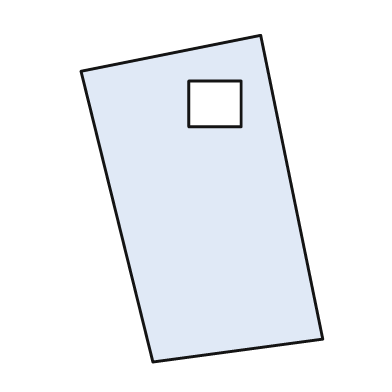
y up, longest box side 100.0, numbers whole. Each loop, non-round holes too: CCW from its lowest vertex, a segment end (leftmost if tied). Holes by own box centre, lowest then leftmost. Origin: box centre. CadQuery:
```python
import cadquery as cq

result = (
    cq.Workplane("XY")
    .moveTo(-15.0, -50.0)
    .lineTo(37.0, -43.0)
    .lineTo(18.0, 50.0)
    .lineTo(-37.0, 39.0)
    .close()
    .moveTo(-4.0, 22.0)
    .lineTo(12.0, 22.0)
    .lineTo(12.0, 36.0)
    .lineTo(-4.0, 36.0)
    .close()
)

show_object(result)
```